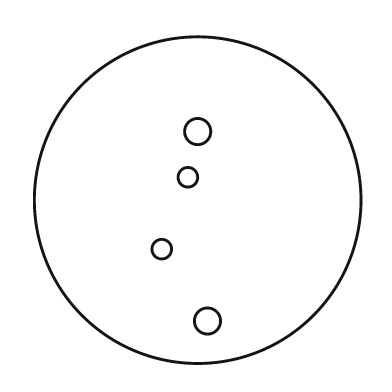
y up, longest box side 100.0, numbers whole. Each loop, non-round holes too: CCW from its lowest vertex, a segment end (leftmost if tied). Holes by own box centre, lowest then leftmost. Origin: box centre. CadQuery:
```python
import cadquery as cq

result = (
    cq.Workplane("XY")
    .moveTo(0.0, 0.0)
    .circle(50.0)
    .moveTo(3.0, -37.0)
    .circle(4.0)
    .moveTo(-11.0, -15.0)
    .circle(3.0)
    .moveTo(-3.0, 7.0)
    .circle(3.0)
    .moveTo(0.0, 21.0)
    .circle(4.0)
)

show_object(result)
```